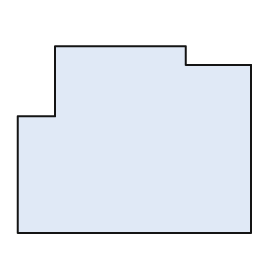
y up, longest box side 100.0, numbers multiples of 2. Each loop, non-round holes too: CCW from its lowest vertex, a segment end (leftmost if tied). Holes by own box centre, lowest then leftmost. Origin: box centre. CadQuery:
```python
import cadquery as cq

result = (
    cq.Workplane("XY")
    .moveTo(-50.0, -40.0)
    .lineTo(50.0, -40.0)
    .lineTo(50.0, 32.0)
    .lineTo(22.0, 32.0)
    .lineTo(22.0, 40.0)
    .lineTo(-34.0, 40.0)
    .lineTo(-34.0, 10.0)
    .lineTo(-50.0, 10.0)
    .close()
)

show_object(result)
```